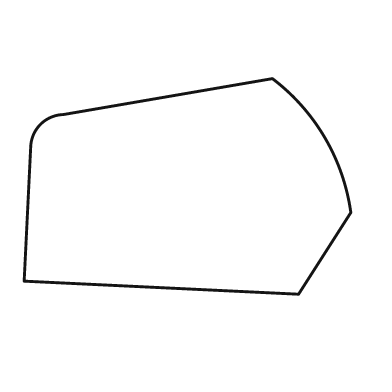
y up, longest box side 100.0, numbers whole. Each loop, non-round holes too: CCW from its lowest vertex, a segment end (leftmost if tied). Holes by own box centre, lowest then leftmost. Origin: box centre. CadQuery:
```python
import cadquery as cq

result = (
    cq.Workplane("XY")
    .moveTo(34.0, -33.0)
    .lineTo(50.0, -8.0)
    .threePointArc((42.0, 15.0), (26.0, 33.0))
    .lineTo(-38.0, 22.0)
    .threePointArc((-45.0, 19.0), (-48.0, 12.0))
    .lineTo(-50.0, -29.0)
    .close()
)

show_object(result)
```